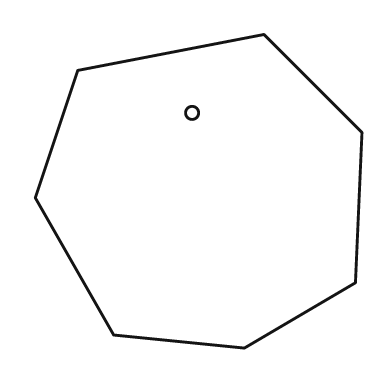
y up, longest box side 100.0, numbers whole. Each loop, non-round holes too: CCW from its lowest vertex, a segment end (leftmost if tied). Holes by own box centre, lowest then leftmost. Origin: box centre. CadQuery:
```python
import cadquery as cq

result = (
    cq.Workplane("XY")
    .moveTo(14.0, -48.0)
    .lineTo(48.0, -28.0)
    .lineTo(50.0, 18.0)
    .lineTo(20.0, 48.0)
    .lineTo(-37.0, 37.0)
    .lineTo(-50.0, -2.0)
    .lineTo(-26.0, -44.0)
    .close()
    .moveTo(-2.0, 24.0)
    .circle(2.0)
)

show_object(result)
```